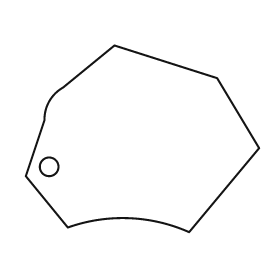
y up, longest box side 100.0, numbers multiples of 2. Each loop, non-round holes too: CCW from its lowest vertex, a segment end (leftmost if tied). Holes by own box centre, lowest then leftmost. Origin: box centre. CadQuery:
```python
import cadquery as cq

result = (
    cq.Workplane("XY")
    .moveTo(20.0, -40.0)
    .lineTo(50.0, -4.0)
    .lineTo(32.0, 26.0)
    .lineTo(-12.0, 40.0)
    .lineTo(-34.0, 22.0)
    .threePointArc((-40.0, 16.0), (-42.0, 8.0))
    .lineTo(-50.0, -16.0)
    .lineTo(-32.0, -38.0)
    .threePointArc((-6.0, -34.0), (20.0, -40.0))
    .close()
    .moveTo(-40.0, -12.0)
    .circle(4.0)
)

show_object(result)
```